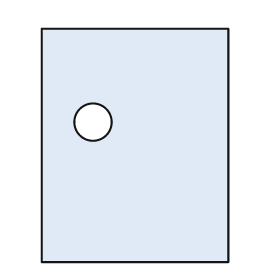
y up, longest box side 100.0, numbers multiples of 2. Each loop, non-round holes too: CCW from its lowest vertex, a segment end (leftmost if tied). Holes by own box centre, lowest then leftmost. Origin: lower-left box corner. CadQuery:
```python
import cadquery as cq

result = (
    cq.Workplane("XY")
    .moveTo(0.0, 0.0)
    .lineTo(80.0, 0.0)
    .lineTo(80.0, 100.0)
    .lineTo(0.0, 100.0)
    .close()
    .moveTo(22.0, 60.0)
    .circle(8.0)
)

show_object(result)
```